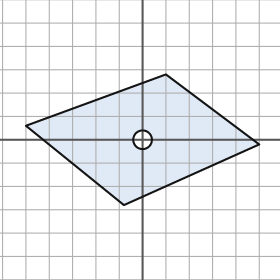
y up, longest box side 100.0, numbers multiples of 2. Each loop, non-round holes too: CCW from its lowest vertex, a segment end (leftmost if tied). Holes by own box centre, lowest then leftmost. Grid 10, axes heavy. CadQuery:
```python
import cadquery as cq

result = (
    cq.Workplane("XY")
    .moveTo(-8.0, -28.0)
    .lineTo(50.0, -2.0)
    .lineTo(10.0, 28.0)
    .lineTo(-50.0, 6.0)
    .close()
    .moveTo(0.0, 0.0)
    .circle(4.0)
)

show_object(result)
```